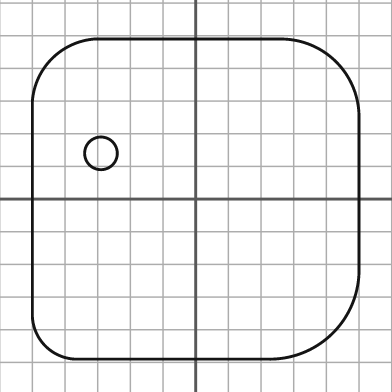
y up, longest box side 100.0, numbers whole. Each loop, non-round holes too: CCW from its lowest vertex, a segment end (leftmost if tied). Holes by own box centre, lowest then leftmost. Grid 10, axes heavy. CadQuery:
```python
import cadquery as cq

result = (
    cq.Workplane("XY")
    .moveTo(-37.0, -49.0)
    .lineTo(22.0, -49.0)
    .threePointArc((42.0, -41.0), (50.0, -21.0))
    .lineTo(50.0, 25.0)
    .threePointArc((43.0, 42.0), (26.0, 49.0))
    .lineTo(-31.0, 49.0)
    .threePointArc((-44.0, 43.0), (-50.0, 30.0))
    .lineTo(-50.0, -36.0)
    .threePointArc((-46.0, -45.0), (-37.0, -49.0))
    .close()
    .moveTo(-29.0, 14.0)
    .circle(5.0)
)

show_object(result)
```